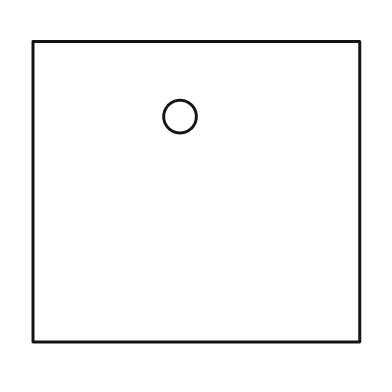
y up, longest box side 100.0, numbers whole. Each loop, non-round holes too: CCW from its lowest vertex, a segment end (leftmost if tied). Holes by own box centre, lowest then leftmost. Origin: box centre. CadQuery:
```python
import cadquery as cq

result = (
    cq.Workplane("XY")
    .moveTo(-50.0, -46.0)
    .lineTo(50.0, -46.0)
    .lineTo(50.0, 46.0)
    .lineTo(-50.0, 46.0)
    .close()
    .moveTo(-5.0, 23.0)
    .circle(5.0)
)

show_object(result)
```